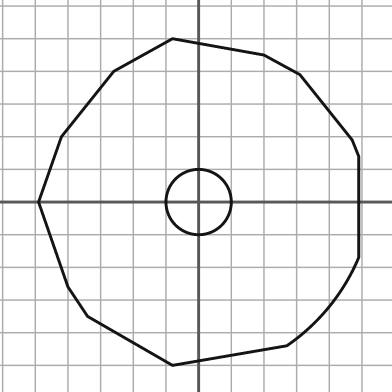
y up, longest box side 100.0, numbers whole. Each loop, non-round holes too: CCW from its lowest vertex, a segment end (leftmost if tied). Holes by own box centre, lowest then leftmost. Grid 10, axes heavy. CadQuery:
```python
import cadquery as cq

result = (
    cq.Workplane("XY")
    .moveTo(-8.0, -50.0)
    .lineTo(27.0, -44.0)
    .threePointArc((40.0, -32.0), (49.0, -17.0))
    .lineTo(49.0, 14.0)
    .lineTo(47.0, 19.0)
    .lineTo(31.0, 39.0)
    .lineTo(20.0, 45.0)
    .lineTo(-8.0, 50.0)
    .lineTo(-26.0, 40.0)
    .lineTo(-42.0, 20.0)
    .lineTo(-49.0, 0.0)
    .lineTo(-40.0, -26.0)
    .lineTo(-34.0, -35.0)
    .close()
    .moveTo(0.0, 0.0)
    .circle(10.0)
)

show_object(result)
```